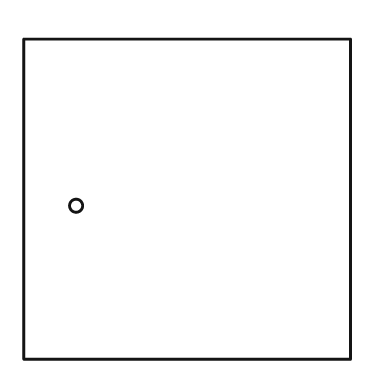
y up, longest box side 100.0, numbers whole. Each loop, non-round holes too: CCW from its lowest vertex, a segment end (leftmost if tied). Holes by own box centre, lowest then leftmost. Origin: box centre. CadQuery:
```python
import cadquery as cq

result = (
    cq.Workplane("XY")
    .moveTo(-50.0, -49.0)
    .lineTo(50.0, -49.0)
    .lineTo(50.0, 49.0)
    .lineTo(-50.0, 49.0)
    .close()
    .moveTo(-34.0, -2.0)
    .circle(2.0)
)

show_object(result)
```